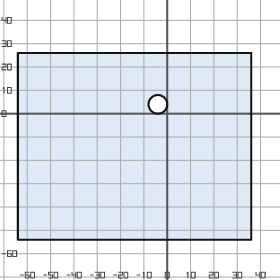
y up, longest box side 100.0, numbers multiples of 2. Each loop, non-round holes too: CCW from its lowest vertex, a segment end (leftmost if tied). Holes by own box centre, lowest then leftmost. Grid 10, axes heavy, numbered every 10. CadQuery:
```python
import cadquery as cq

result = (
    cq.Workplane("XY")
    .moveTo(-64.0, -54.0)
    .lineTo(36.0, -54.0)
    .lineTo(36.0, 26.0)
    .lineTo(-64.0, 26.0)
    .close()
    .moveTo(-4.0, 4.0)
    .circle(4.0)
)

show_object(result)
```